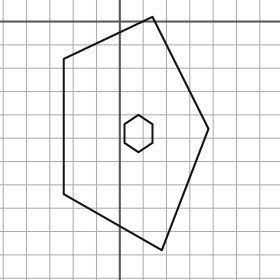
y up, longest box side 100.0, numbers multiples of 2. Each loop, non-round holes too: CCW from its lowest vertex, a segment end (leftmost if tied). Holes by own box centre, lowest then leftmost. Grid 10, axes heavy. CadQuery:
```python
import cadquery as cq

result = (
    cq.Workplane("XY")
    .moveTo(18.0, -98.0)
    .lineTo(38.0, -46.0)
    .lineTo(14.0, 2.0)
    .lineTo(-24.0, -16.0)
    .lineTo(-24.0, -74.0)
    .close()
    .moveTo(8.0, -56.0)
    .lineTo(14.0, -52.0)
    .lineTo(14.0, -44.0)
    .lineTo(8.0, -40.0)
    .lineTo(2.0, -44.0)
    .lineTo(2.0, -52.0)
    .close()
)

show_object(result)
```